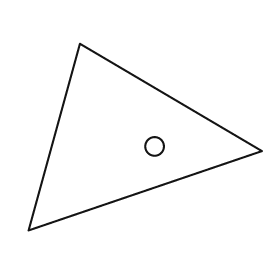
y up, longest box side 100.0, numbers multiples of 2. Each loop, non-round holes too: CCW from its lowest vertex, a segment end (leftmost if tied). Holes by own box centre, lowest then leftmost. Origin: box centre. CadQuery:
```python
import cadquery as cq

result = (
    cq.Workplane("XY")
    .moveTo(-50.0, -40.0)
    .lineTo(50.0, -6.0)
    .lineTo(-28.0, 40.0)
    .close()
    .moveTo(4.0, -4.0)
    .circle(4.0)
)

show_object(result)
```